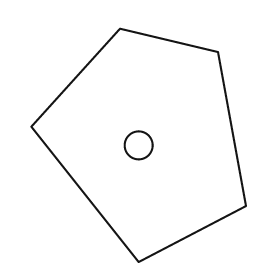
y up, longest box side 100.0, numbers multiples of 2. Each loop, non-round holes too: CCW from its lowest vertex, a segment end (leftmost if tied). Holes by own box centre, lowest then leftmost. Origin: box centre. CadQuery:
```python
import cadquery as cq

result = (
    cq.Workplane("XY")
    .moveTo(0.0, -50.0)
    .lineTo(46.0, -26.0)
    .lineTo(34.0, 40.0)
    .lineTo(-8.0, 50.0)
    .lineTo(-46.0, 8.0)
    .close()
    .moveTo(0.0, 0.0)
    .circle(6.0)
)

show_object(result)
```